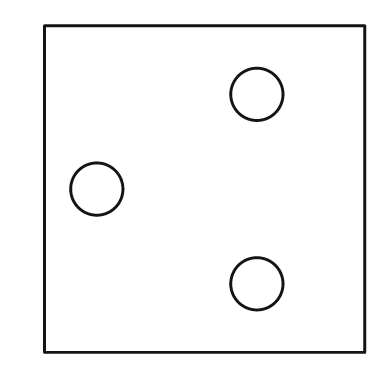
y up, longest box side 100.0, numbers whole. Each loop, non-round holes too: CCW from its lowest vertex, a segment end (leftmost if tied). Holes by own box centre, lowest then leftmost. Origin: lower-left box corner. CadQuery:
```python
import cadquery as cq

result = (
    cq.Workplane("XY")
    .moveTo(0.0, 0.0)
    .lineTo(98.0, 0.0)
    .lineTo(98.0, 100.0)
    .lineTo(0.0, 100.0)
    .close()
    .moveTo(65.0, 21.0)
    .circle(8.0)
    .moveTo(16.0, 50.0)
    .circle(8.0)
    .moveTo(65.0, 79.0)
    .circle(8.0)
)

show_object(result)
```